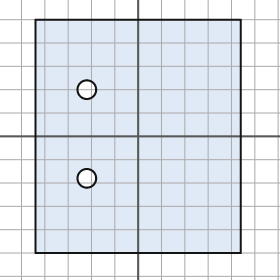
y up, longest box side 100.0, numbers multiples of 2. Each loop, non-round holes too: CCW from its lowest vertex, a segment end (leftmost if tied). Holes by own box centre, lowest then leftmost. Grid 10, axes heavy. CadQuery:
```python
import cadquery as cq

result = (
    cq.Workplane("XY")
    .moveTo(-44.0, -50.0)
    .lineTo(44.0, -50.0)
    .lineTo(44.0, 50.0)
    .lineTo(-44.0, 50.0)
    .close()
    .moveTo(-22.0, -18.0)
    .circle(4.0)
    .moveTo(-22.0, 20.0)
    .circle(4.0)
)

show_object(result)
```